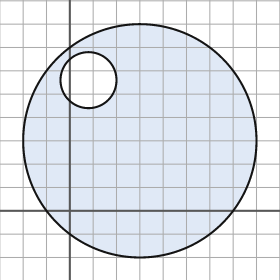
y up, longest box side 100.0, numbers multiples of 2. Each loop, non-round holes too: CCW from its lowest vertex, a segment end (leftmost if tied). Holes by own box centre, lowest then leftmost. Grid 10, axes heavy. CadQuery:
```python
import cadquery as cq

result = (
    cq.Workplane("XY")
    .moveTo(30.0, 30.0)
    .circle(50.0)
    .moveTo(8.0, 56.0)
    .circle(12.0)
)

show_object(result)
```